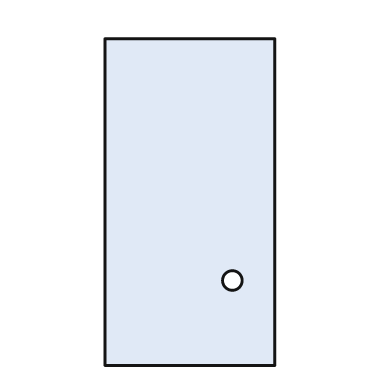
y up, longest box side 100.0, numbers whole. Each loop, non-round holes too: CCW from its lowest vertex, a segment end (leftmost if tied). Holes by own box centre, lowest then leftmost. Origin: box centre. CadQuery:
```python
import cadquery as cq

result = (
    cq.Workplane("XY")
    .moveTo(-26.0, -50.0)
    .lineTo(26.0, -50.0)
    .lineTo(26.0, 50.0)
    .lineTo(-26.0, 50.0)
    .close()
    .moveTo(13.0, -24.0)
    .circle(3.0)
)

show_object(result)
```